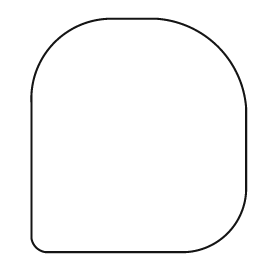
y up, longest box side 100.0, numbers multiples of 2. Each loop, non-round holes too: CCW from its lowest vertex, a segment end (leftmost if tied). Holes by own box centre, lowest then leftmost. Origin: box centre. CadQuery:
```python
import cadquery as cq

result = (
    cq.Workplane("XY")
    .moveTo(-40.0, -50.0)
    .lineTo(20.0, -50.0)
    .threePointArc((38.0, -42.0), (46.0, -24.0))
    .lineTo(46.0, 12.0)
    .threePointArc((34.0, 38.0), (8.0, 50.0))
    .lineTo(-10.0, 50.0)
    .threePointArc((-36.0, 40.0), (-46.0, 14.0))
    .lineTo(-46.0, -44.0)
    .threePointArc((-44.0, -48.0), (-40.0, -50.0))
    .close()
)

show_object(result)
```